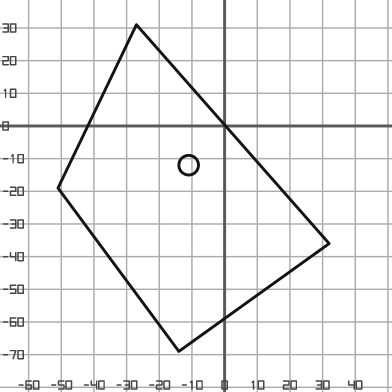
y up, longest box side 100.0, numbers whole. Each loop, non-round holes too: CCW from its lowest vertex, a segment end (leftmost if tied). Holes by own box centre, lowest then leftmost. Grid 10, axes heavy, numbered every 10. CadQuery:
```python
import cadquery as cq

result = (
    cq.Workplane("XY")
    .moveTo(-14.0, -69.0)
    .lineTo(32.0, -36.0)
    .lineTo(-27.0, 31.0)
    .lineTo(-51.0, -19.0)
    .close()
    .moveTo(-11.0, -12.0)
    .circle(3.0)
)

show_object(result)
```